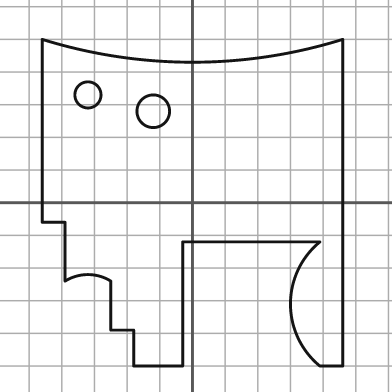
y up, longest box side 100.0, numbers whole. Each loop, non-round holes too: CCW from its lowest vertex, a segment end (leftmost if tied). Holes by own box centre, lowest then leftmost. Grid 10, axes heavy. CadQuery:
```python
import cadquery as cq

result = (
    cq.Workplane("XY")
    .moveTo(-18.0, -50.0)
    .lineTo(-3.0, -50.0)
    .lineTo(-3.0, -12.0)
    .lineTo(39.0, -12.0)
    .threePointArc((30.0, -31.0), (39.0, -50.0))
    .lineTo(46.0, -50.0)
    .lineTo(46.0, 50.0)
    .threePointArc((0.0, 43.0), (-46.0, 50.0))
    .lineTo(-46.0, -6.0)
    .lineTo(-39.0, -6.0)
    .lineTo(-39.0, -24.0)
    .threePointArc((-32.0, -22.0), (-25.0, -24.0))
    .lineTo(-25.0, -39.0)
    .lineTo(-18.0, -39.0)
    .close()
    .moveTo(-12.0, 28.0)
    .circle(5.0)
    .moveTo(-32.0, 33.0)
    .circle(4.0)
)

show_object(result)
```